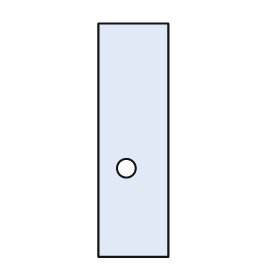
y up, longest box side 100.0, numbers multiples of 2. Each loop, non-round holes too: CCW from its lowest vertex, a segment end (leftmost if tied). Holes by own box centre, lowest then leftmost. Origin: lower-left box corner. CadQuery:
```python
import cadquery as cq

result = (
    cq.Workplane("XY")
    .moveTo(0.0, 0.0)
    .lineTo(30.0, 0.0)
    .lineTo(30.0, 100.0)
    .lineTo(0.0, 100.0)
    .close()
    .moveTo(12.0, 38.0)
    .circle(4.0)
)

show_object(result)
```